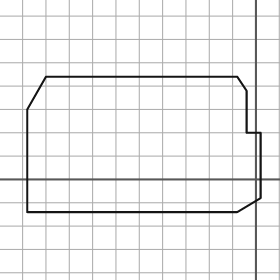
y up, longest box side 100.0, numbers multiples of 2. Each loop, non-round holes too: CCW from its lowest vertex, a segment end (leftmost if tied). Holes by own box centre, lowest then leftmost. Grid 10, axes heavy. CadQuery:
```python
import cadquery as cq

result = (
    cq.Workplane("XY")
    .moveTo(-98.0, -14.0)
    .lineTo(-8.0, -14.0)
    .lineTo(2.0, -8.0)
    .lineTo(2.0, 20.0)
    .lineTo(-4.0, 20.0)
    .lineTo(-4.0, 38.0)
    .lineTo(-8.0, 44.0)
    .lineTo(-90.0, 44.0)
    .lineTo(-98.0, 30.0)
    .close()
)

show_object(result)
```